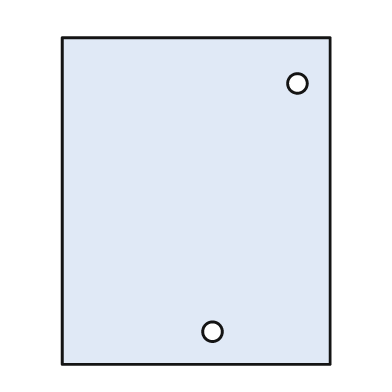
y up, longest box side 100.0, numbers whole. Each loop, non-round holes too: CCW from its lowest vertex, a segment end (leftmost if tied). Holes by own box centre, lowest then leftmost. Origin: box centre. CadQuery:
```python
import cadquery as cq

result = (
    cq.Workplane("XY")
    .moveTo(-41.0, -50.0)
    .lineTo(41.0, -50.0)
    .lineTo(41.0, 50.0)
    .lineTo(-41.0, 50.0)
    .close()
    .moveTo(5.0, -40.0)
    .circle(3.0)
    .moveTo(31.0, 36.0)
    .circle(3.0)
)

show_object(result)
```